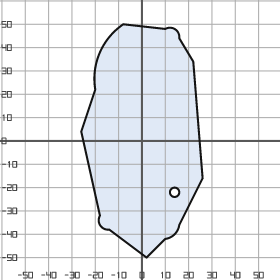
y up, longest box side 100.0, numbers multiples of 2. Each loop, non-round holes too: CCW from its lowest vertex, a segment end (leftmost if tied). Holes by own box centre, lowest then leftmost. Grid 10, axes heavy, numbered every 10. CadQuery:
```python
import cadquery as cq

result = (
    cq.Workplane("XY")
    .moveTo(2.0, -50.0)
    .lineTo(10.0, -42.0)
    .threePointArc((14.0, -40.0), (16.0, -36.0))
    .lineTo(26.0, -16.0)
    .lineTo(22.0, 34.0)
    .lineTo(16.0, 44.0)
    .threePointArc((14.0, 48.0), (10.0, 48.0))
    .lineTo(-8.0, 50.0)
    .threePointArc((-18.0, 38.0), (-20.0, 22.0))
    .lineTo(-26.0, 4.0)
    .lineTo(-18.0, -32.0)
    .threePointArc((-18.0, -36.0), (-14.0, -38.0))
    .close()
    .moveTo(14.0, -22.0)
    .circle(2.0)
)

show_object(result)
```